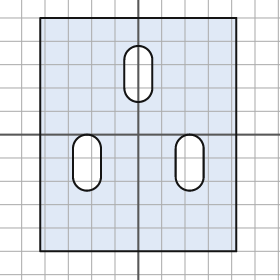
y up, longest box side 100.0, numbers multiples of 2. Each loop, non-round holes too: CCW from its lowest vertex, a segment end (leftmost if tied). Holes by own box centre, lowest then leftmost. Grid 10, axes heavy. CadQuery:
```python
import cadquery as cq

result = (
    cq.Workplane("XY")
    .moveTo(-42.0, -50.0)
    .lineTo(42.0, -50.0)
    .lineTo(42.0, 50.0)
    .lineTo(-42.0, 50.0)
    .close()
    .moveTo(-28.0, -18.0)
    .threePointArc((-22.0, -24.0), (-16.0, -18.0))
    .lineTo(-16.0, -6.0)
    .threePointArc((-22.0, 0.0), (-28.0, -6.0))
    .close()
    .moveTo(16.0, -18.0)
    .threePointArc((22.0, -24.0), (28.0, -18.0))
    .lineTo(28.0, -6.0)
    .threePointArc((22.0, 0.0), (16.0, -6.0))
    .close()
    .moveTo(-6.0, 20.0)
    .threePointArc((0.0, 14.0), (6.0, 20.0))
    .lineTo(6.0, 32.0)
    .threePointArc((0.0, 38.0), (-6.0, 32.0))
    .close()
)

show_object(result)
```